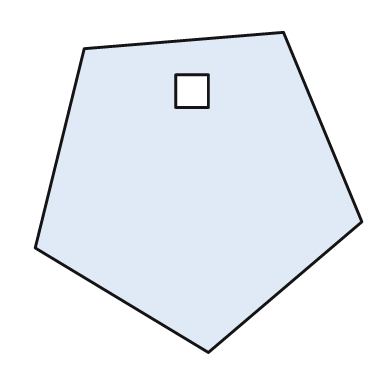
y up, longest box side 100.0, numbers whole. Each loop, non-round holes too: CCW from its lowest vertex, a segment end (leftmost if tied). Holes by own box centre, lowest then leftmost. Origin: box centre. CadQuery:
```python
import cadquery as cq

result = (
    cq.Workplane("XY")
    .moveTo(3.0, -49.0)
    .lineTo(50.0, -9.0)
    .lineTo(26.0, 49.0)
    .lineTo(-35.0, 44.0)
    .lineTo(-50.0, -17.0)
    .close()
    .moveTo(-7.0, 26.0)
    .lineTo(3.0, 26.0)
    .lineTo(3.0, 36.0)
    .lineTo(-7.0, 36.0)
    .close()
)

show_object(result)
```